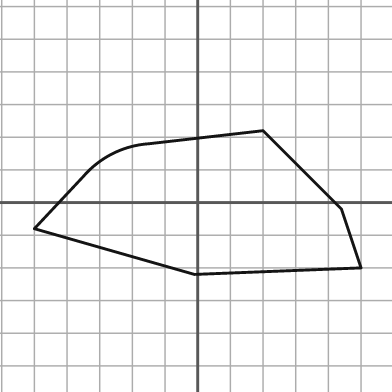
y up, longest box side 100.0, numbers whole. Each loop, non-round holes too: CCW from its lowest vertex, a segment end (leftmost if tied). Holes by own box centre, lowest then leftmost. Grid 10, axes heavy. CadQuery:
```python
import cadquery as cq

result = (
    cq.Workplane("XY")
    .moveTo(-1.0, -22.0)
    .lineTo(50.0, -20.0)
    .lineTo(44.0, -2.0)
    .lineTo(20.0, 22.0)
    .lineTo(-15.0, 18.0)
    .threePointArc((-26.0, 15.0), (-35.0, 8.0))
    .lineTo(-50.0, -8.0)
    .close()
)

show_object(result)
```